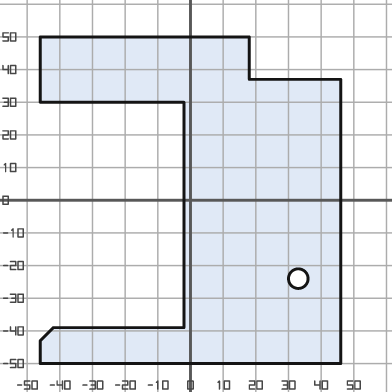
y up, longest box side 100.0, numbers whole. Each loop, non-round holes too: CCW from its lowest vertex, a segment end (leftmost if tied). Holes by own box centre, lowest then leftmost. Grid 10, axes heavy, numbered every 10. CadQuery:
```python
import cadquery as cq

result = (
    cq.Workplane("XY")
    .moveTo(-46.0, -50.0)
    .lineTo(46.0, -50.0)
    .lineTo(46.0, 37.0)
    .lineTo(18.0, 37.0)
    .lineTo(18.0, 50.0)
    .lineTo(-46.0, 50.0)
    .lineTo(-46.0, 30.0)
    .lineTo(-2.0, 30.0)
    .lineTo(-2.0, -39.0)
    .lineTo(-42.0, -39.0)
    .lineTo(-46.0, -43.0)
    .close()
    .moveTo(33.0, -24.0)
    .circle(3.0)
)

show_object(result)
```